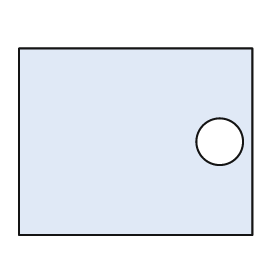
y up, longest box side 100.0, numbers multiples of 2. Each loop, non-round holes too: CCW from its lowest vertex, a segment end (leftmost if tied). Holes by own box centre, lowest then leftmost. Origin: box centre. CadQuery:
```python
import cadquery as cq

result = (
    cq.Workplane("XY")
    .moveTo(-50.0, -40.0)
    .lineTo(50.0, -40.0)
    .lineTo(50.0, 40.0)
    .lineTo(-50.0, 40.0)
    .close()
    .moveTo(36.0, 0.0)
    .circle(10.0)
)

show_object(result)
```